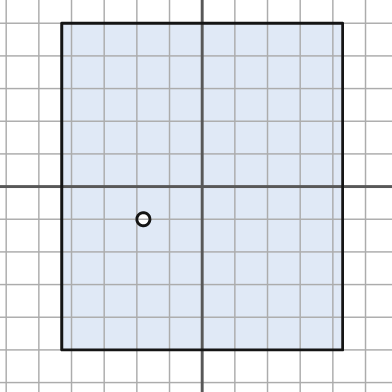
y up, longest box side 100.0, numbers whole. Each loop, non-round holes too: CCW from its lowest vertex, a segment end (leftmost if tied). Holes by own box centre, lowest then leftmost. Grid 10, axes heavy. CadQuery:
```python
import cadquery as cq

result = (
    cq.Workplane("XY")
    .moveTo(-43.0, -50.0)
    .lineTo(43.0, -50.0)
    .lineTo(43.0, 50.0)
    .lineTo(-43.0, 50.0)
    .close()
    .moveTo(-18.0, -10.0)
    .circle(2.0)
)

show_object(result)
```